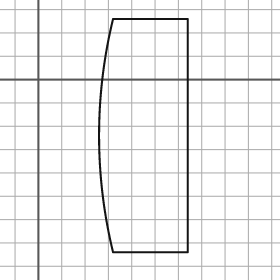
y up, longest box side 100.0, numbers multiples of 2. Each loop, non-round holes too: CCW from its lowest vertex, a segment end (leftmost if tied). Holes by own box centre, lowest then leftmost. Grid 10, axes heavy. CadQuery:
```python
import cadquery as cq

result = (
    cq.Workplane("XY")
    .moveTo(32.0, -74.0)
    .lineTo(64.0, -74.0)
    .lineTo(64.0, 26.0)
    .lineTo(32.0, 26.0)
    .threePointArc((26.0, -24.0), (32.0, -74.0))
    .close()
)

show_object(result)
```